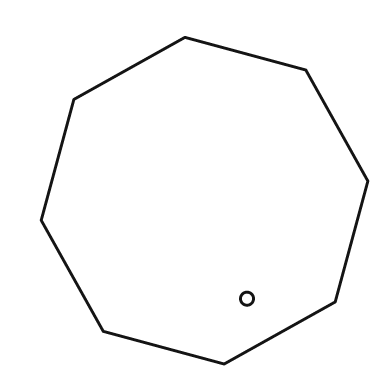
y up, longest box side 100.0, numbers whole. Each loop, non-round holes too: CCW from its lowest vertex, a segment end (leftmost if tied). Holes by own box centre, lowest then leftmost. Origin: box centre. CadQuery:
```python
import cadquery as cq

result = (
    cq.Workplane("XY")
    .moveTo(6.0, -50.0)
    .lineTo(40.0, -31.0)
    .lineTo(50.0, 6.0)
    .lineTo(31.0, 40.0)
    .lineTo(-6.0, 50.0)
    .lineTo(-40.0, 31.0)
    .lineTo(-50.0, -6.0)
    .lineTo(-31.0, -40.0)
    .close()
    .moveTo(13.0, -30.0)
    .circle(2.0)
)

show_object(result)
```